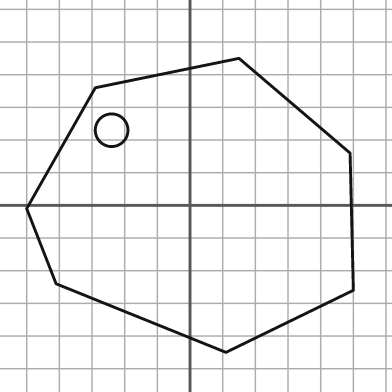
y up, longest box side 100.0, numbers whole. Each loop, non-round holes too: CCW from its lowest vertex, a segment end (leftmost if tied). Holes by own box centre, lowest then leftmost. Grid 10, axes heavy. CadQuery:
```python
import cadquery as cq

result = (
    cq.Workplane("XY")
    .moveTo(11.0, -45.0)
    .lineTo(50.0, -26.0)
    .lineTo(49.0, 16.0)
    .lineTo(15.0, 45.0)
    .lineTo(-29.0, 36.0)
    .lineTo(-50.0, -1.0)
    .lineTo(-41.0, -24.0)
    .close()
    .moveTo(-24.0, 23.0)
    .circle(5.0)
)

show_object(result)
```